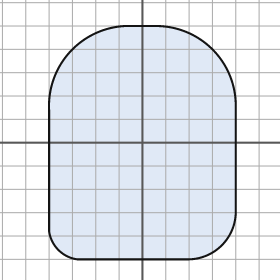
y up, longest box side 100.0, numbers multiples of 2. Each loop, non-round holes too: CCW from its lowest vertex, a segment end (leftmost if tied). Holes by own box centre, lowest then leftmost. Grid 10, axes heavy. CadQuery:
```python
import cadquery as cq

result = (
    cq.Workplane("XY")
    .moveTo(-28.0, -50.0)
    .lineTo(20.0, -50.0)
    .threePointArc((34.0, -44.0), (40.0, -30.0))
    .lineTo(40.0, 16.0)
    .threePointArc((30.0, 40.0), (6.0, 50.0))
    .lineTo(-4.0, 50.0)
    .threePointArc((-30.0, 40.0), (-40.0, 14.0))
    .lineTo(-40.0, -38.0)
    .threePointArc((-36.0, -46.0), (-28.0, -50.0))
    .close()
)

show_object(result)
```